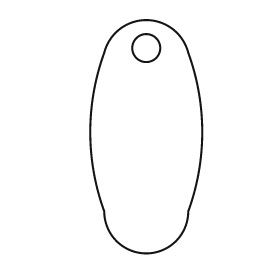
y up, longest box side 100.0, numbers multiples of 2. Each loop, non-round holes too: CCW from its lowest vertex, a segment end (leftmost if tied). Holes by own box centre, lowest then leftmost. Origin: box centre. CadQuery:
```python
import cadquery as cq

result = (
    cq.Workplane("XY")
    .moveTo(-18.0, -32.0)
    .threePointArc((0.0, -50.0), (18.0, -32.0))
    .threePointArc((24.0, 2.0), (18.0, 36.0))
    .threePointArc((0.0, 50.0), (-18.0, 36.0))
    .threePointArc((-24.0, 2.0), (-18.0, -32.0))
    .close()
    .moveTo(0.0, 38.0)
    .circle(6.0)
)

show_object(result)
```